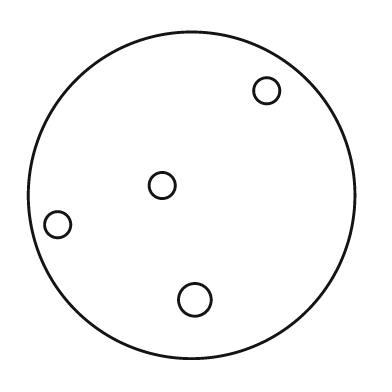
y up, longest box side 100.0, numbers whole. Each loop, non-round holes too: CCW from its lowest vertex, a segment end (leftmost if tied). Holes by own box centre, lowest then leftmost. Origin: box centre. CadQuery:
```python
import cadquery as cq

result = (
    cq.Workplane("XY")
    .moveTo(0.0, 0.0)
    .circle(50.0)
    .moveTo(1.0, -32.0)
    .circle(5.0)
    .moveTo(-41.0, -9.0)
    .circle(4.0)
    .moveTo(-9.0, 3.0)
    .circle(4.0)
    .moveTo(23.0, 32.0)
    .circle(4.0)
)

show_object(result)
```